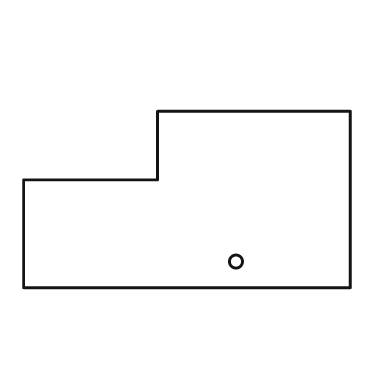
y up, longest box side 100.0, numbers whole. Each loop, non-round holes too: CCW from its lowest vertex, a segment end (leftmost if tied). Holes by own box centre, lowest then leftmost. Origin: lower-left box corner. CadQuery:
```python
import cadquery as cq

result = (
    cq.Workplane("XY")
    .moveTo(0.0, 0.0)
    .lineTo(100.0, 0.0)
    .lineTo(100.0, 54.0)
    .lineTo(41.0, 54.0)
    .lineTo(41.0, 33.0)
    .lineTo(0.0, 33.0)
    .close()
    .moveTo(65.0, 8.0)
    .circle(2.0)
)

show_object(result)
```